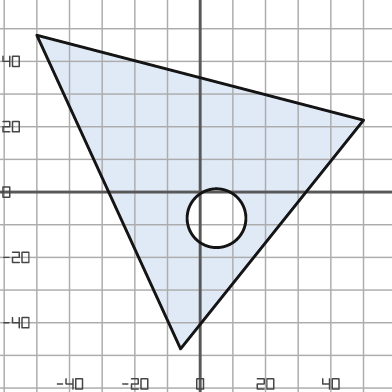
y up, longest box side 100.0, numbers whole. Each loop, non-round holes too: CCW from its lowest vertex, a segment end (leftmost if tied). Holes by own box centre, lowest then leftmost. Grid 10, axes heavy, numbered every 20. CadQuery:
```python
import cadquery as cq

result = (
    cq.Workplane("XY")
    .moveTo(-6.0, -48.0)
    .lineTo(50.0, 22.0)
    .lineTo(-50.0, 48.0)
    .close()
    .moveTo(5.0, -8.0)
    .circle(9.0)
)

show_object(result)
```